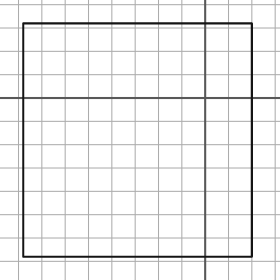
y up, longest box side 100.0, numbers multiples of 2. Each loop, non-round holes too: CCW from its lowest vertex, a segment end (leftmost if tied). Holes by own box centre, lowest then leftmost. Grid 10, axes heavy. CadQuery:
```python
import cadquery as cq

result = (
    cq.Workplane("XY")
    .moveTo(-78.0, -68.0)
    .lineTo(20.0, -68.0)
    .lineTo(20.0, 32.0)
    .lineTo(-78.0, 32.0)
    .close()
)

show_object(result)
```